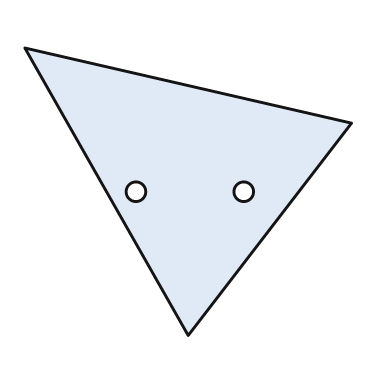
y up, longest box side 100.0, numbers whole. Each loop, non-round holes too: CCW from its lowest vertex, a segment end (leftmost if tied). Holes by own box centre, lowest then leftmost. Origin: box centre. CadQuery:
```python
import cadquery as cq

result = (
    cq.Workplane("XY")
    .moveTo(0.0, -44.0)
    .lineTo(50.0, 21.0)
    .lineTo(-50.0, 44.0)
    .close()
    .moveTo(-16.0, 0.0)
    .circle(3.0)
    .moveTo(17.0, 0.0)
    .circle(3.0)
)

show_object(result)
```